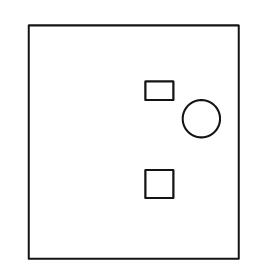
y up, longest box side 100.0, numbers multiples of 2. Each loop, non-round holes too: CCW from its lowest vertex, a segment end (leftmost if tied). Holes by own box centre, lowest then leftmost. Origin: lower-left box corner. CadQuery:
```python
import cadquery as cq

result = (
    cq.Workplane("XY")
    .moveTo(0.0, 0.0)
    .lineTo(90.0, 0.0)
    .lineTo(90.0, 100.0)
    .lineTo(0.0, 100.0)
    .close()
    .moveTo(50.0, 26.0)
    .lineTo(62.0, 26.0)
    .lineTo(62.0, 38.0)
    .lineTo(50.0, 38.0)
    .close()
    .moveTo(74.0, 60.0)
    .circle(8.0)
    .moveTo(50.0, 68.0)
    .lineTo(62.0, 68.0)
    .lineTo(62.0, 76.0)
    .lineTo(50.0, 76.0)
    .close()
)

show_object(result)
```